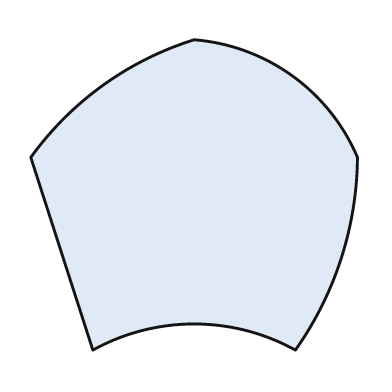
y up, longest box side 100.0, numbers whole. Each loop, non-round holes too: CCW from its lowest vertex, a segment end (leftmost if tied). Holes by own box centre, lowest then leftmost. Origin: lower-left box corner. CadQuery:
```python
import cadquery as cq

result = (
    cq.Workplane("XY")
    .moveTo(19.0, 0.0)
    .threePointArc((50.0, 8.0), (81.0, 0.0))
    .threePointArc((95.0, 28.0), (100.0, 59.0))
    .threePointArc((80.0, 84.0), (50.0, 95.0))
    .threePointArc((22.0, 81.0), (0.0, 59.0))
    .close()
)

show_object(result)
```